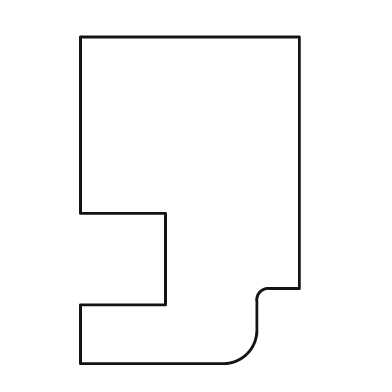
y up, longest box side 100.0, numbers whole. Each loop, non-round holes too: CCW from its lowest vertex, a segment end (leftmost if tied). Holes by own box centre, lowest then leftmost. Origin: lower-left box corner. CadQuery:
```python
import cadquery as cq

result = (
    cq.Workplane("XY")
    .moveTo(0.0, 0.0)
    .lineTo(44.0, 0.0)
    .threePointArc((51.0, 3.0), (54.0, 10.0))
    .lineTo(54.0, 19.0)
    .threePointArc((55.0, 22.0), (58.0, 23.0))
    .lineTo(67.0, 23.0)
    .lineTo(67.0, 100.0)
    .lineTo(0.0, 100.0)
    .lineTo(0.0, 46.0)
    .lineTo(26.0, 46.0)
    .lineTo(26.0, 18.0)
    .lineTo(0.0, 18.0)
    .close()
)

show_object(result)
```